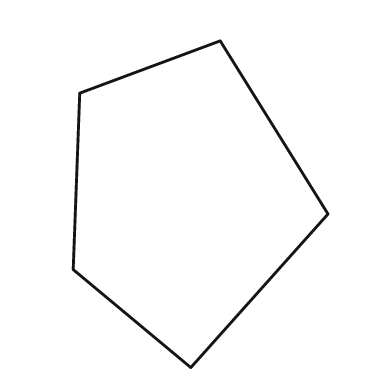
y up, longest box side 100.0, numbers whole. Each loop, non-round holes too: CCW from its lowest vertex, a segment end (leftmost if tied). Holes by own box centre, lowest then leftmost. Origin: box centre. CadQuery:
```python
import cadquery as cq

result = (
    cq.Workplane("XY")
    .moveTo(-3.0, -50.0)
    .lineTo(39.0, -3.0)
    .lineTo(6.0, 50.0)
    .lineTo(-37.0, 34.0)
    .lineTo(-39.0, -20.0)
    .close()
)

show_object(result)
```